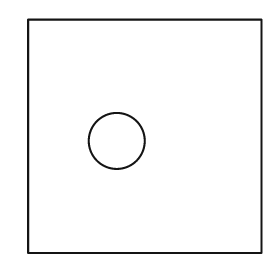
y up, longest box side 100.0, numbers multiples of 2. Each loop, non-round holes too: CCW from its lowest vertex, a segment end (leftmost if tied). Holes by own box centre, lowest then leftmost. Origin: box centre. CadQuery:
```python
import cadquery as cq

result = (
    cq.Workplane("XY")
    .moveTo(-50.0, -50.0)
    .lineTo(50.0, -50.0)
    .lineTo(50.0, 50.0)
    .lineTo(-50.0, 50.0)
    .close()
    .moveTo(-12.0, -2.0)
    .circle(12.0)
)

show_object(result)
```